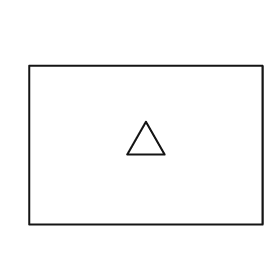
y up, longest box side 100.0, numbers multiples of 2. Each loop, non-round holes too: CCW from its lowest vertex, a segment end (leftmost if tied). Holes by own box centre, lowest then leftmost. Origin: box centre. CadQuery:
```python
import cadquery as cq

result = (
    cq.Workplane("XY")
    .moveTo(-50.0, -34.0)
    .lineTo(50.0, -34.0)
    .lineTo(50.0, 34.0)
    .lineTo(-50.0, 34.0)
    .close()
    .moveTo(-8.0, -4.0)
    .lineTo(8.0, -4.0)
    .lineTo(0.0, 10.0)
    .close()
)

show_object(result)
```